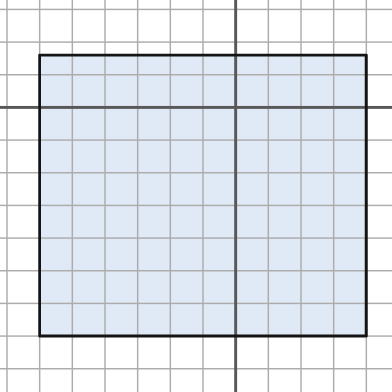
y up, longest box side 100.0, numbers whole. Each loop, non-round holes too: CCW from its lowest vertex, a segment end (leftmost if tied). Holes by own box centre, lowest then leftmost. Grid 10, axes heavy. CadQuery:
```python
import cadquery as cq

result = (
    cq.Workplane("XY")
    .moveTo(-60.0, -70.0)
    .lineTo(40.0, -70.0)
    .lineTo(40.0, 16.0)
    .lineTo(-60.0, 16.0)
    .close()
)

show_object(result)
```